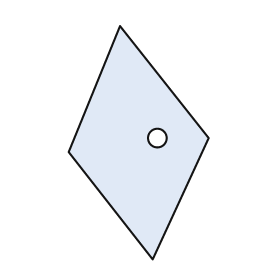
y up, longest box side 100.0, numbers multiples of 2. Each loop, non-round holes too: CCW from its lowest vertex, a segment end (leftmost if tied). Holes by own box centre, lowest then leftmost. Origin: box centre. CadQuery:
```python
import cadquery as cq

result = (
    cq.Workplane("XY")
    .moveTo(6.0, -50.0)
    .lineTo(30.0, 2.0)
    .lineTo(-8.0, 50.0)
    .lineTo(-30.0, -4.0)
    .close()
    .moveTo(8.0, 2.0)
    .circle(4.0)
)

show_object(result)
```